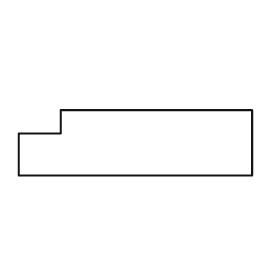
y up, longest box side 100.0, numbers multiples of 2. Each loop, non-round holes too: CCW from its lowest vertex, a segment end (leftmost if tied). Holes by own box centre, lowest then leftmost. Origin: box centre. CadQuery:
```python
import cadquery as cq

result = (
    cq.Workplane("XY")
    .moveTo(-50.0, -14.0)
    .lineTo(50.0, -14.0)
    .lineTo(50.0, 14.0)
    .lineTo(-32.0, 14.0)
    .lineTo(-32.0, 4.0)
    .lineTo(-50.0, 4.0)
    .close()
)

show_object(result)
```